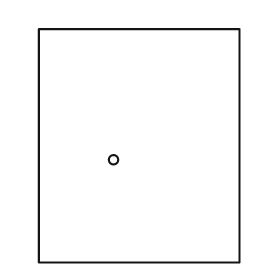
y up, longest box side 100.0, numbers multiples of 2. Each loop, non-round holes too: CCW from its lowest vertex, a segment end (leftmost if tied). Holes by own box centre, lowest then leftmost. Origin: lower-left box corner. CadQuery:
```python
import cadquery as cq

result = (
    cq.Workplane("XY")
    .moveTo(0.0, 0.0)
    .lineTo(86.0, 0.0)
    .lineTo(86.0, 100.0)
    .lineTo(0.0, 100.0)
    .close()
    .moveTo(32.0, 44.0)
    .circle(2.0)
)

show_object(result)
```